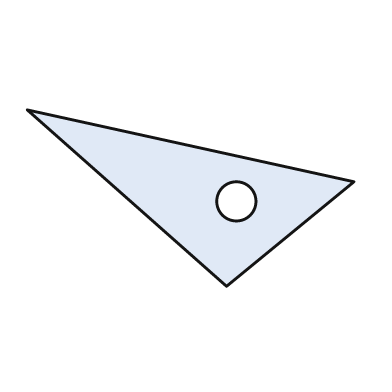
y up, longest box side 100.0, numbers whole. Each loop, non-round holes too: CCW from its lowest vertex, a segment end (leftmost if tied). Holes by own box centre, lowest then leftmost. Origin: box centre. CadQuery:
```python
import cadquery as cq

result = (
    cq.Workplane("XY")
    .moveTo(11.0, -27.0)
    .lineTo(50.0, 5.0)
    .lineTo(-50.0, 27.0)
    .close()
    .moveTo(14.0, -1.0)
    .circle(6.0)
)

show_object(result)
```